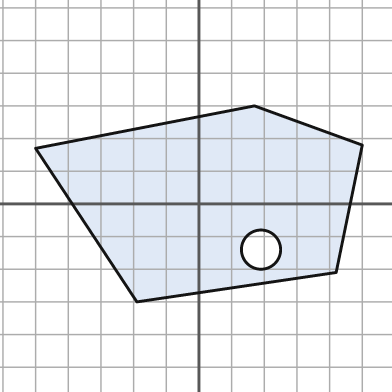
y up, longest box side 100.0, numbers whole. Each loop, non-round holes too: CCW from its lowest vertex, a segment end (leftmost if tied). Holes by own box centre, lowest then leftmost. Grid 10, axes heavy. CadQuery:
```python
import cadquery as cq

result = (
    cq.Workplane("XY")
    .moveTo(-19.0, -30.0)
    .lineTo(42.0, -21.0)
    .lineTo(50.0, 18.0)
    .lineTo(17.0, 30.0)
    .lineTo(-50.0, 17.0)
    .close()
    .moveTo(19.0, -14.0)
    .circle(6.0)
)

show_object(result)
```